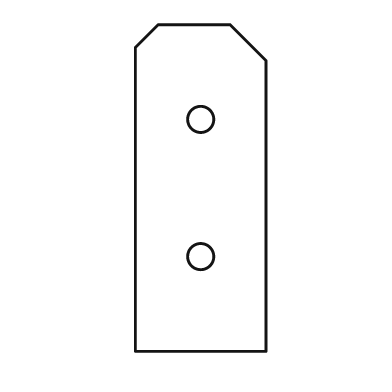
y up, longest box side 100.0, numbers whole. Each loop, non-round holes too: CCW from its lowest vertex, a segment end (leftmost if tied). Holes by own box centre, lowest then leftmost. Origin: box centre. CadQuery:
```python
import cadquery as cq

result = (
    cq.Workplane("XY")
    .moveTo(-20.0, -50.0)
    .lineTo(20.0, -50.0)
    .lineTo(20.0, 39.0)
    .lineTo(9.0, 50.0)
    .lineTo(-13.0, 50.0)
    .lineTo(-20.0, 43.0)
    .close()
    .moveTo(0.0, -21.0)
    .circle(4.0)
    .moveTo(0.0, 21.0)
    .circle(4.0)
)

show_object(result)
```